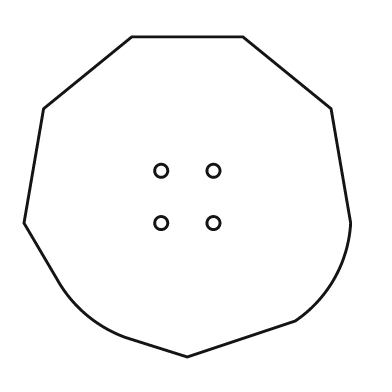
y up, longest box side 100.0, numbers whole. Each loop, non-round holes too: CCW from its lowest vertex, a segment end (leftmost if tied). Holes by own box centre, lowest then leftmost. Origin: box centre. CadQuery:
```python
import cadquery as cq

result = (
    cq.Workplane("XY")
    .moveTo(0.0, -49.0)
    .lineTo(33.0, -38.0)
    .threePointArc((45.0, -25.0), (50.0, -8.0))
    .lineTo(44.0, 27.0)
    .lineTo(17.0, 49.0)
    .lineTo(-17.0, 49.0)
    .lineTo(-44.0, 27.0)
    .lineTo(-50.0, -8.0)
    .lineTo(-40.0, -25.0)
    .threePointArc((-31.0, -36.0), (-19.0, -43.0))
    .close()
    .moveTo(-8.0, -8.0)
    .circle(2.0)
    .moveTo(8.0, -8.0)
    .circle(2.0)
    .moveTo(-8.0, 8.0)
    .circle(2.0)
    .moveTo(8.0, 8.0)
    .circle(2.0)
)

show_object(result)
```